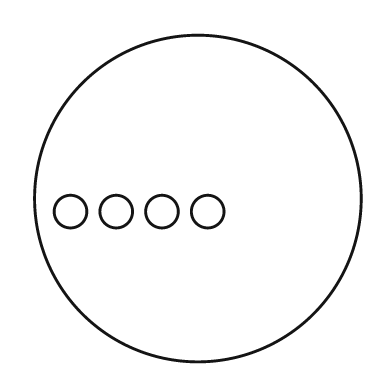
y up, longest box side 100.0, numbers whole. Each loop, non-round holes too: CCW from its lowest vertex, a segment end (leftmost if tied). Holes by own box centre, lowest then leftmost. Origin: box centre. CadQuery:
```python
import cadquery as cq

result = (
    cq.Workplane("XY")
    .moveTo(0.0, 0.0)
    .circle(50.0)
    .moveTo(-39.0, -4.0)
    .circle(5.0)
    .moveTo(-25.0, -4.0)
    .circle(5.0)
    .moveTo(-11.0, -4.0)
    .circle(5.0)
    .moveTo(3.0, -4.0)
    .circle(5.0)
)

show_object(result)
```